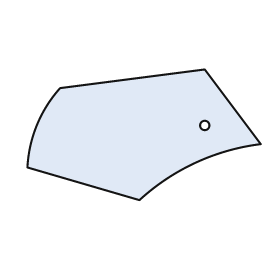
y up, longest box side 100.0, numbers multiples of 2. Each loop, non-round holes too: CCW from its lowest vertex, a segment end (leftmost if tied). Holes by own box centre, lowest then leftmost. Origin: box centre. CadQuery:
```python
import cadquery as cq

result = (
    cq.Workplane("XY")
    .moveTo(-2.0, -28.0)
    .threePointArc((22.0, -12.0), (50.0, -4.0))
    .lineTo(26.0, 28.0)
    .lineTo(-36.0, 20.0)
    .threePointArc((-46.0, 4.0), (-50.0, -14.0))
    .close()
    .moveTo(26.0, 4.0)
    .circle(2.0)
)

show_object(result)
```